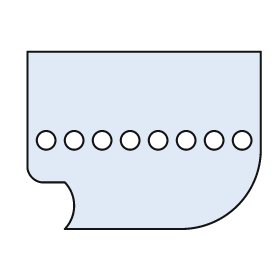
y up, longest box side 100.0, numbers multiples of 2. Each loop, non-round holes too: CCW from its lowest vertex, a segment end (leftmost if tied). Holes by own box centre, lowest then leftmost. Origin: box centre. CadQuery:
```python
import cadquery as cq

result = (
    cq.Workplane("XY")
    .moveTo(-34.0, -38.0)
    .lineTo(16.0, -38.0)
    .threePointArc((40.0, -28.0), (50.0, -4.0))
    .lineTo(50.0, 38.0)
    .lineTo(-50.0, 38.0)
    .lineTo(-50.0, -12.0)
    .threePointArc((-48.0, -16.0), (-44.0, -18.0))
    .lineTo(-34.0, -18.0)
    .threePointArc((-30.0, -28.0), (-34.0, -38.0))
    .close()
    .moveTo(-42.0, 0.0)
    .circle(4.0)
    .moveTo(-30.0, 0.0)
    .circle(4.0)
    .moveTo(-18.0, 0.0)
    .circle(4.0)
    .moveTo(-6.0, 0.0)
    .circle(4.0)
    .moveTo(6.0, 0.0)
    .circle(4.0)
    .moveTo(18.0, 0.0)
    .circle(4.0)
    .moveTo(30.0, 0.0)
    .circle(4.0)
    .moveTo(42.0, 0.0)
    .circle(4.0)
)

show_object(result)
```